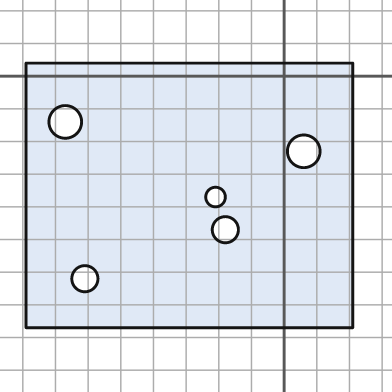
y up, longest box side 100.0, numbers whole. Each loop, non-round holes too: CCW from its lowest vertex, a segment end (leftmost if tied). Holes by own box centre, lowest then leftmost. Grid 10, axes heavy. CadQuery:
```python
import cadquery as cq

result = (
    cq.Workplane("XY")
    .moveTo(-79.0, -77.0)
    .lineTo(21.0, -77.0)
    .lineTo(21.0, 4.0)
    .lineTo(-79.0, 4.0)
    .close()
    .moveTo(-61.0, -62.0)
    .circle(4.0)
    .moveTo(-18.0, -47.0)
    .circle(4.0)
    .moveTo(-21.0, -37.0)
    .circle(3.0)
    .moveTo(6.0, -23.0)
    .circle(5.0)
    .moveTo(-67.0, -14.0)
    .circle(5.0)
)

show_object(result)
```